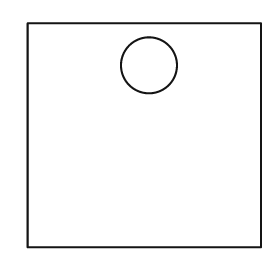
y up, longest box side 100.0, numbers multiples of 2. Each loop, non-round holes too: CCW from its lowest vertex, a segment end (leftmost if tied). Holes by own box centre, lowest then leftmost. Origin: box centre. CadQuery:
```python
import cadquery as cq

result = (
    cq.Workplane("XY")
    .moveTo(-50.0, -48.0)
    .lineTo(50.0, -48.0)
    .lineTo(50.0, 48.0)
    .lineTo(-50.0, 48.0)
    .close()
    .moveTo(2.0, 30.0)
    .circle(12.0)
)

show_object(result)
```